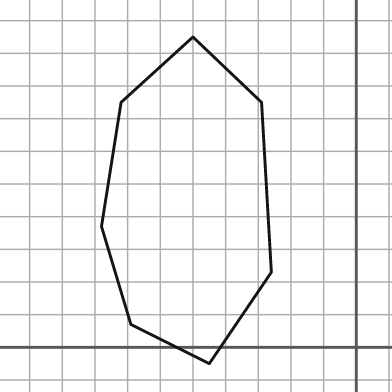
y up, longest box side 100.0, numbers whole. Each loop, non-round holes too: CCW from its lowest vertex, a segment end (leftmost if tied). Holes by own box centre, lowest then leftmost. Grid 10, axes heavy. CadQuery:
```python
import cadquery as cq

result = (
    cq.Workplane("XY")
    .moveTo(-45.0, -5.0)
    .lineTo(-26.0, 23.0)
    .lineTo(-29.0, 75.0)
    .lineTo(-50.0, 95.0)
    .lineTo(-72.0, 75.0)
    .lineTo(-78.0, 37.0)
    .lineTo(-69.0, 7.0)
    .close()
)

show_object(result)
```